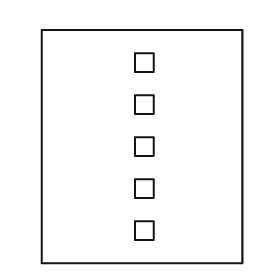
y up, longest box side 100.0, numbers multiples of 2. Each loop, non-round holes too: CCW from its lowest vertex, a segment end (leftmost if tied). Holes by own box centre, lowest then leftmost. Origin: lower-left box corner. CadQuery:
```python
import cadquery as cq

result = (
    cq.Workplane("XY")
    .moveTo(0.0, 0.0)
    .lineTo(86.0, 0.0)
    .lineTo(86.0, 100.0)
    .lineTo(0.0, 100.0)
    .close()
    .moveTo(40.0, 10.0)
    .lineTo(48.0, 10.0)
    .lineTo(48.0, 18.0)
    .lineTo(40.0, 18.0)
    .close()
    .moveTo(40.0, 28.0)
    .lineTo(48.0, 28.0)
    .lineTo(48.0, 36.0)
    .lineTo(40.0, 36.0)
    .close()
    .moveTo(40.0, 46.0)
    .lineTo(48.0, 46.0)
    .lineTo(48.0, 54.0)
    .lineTo(40.0, 54.0)
    .close()
    .moveTo(40.0, 64.0)
    .lineTo(48.0, 64.0)
    .lineTo(48.0, 72.0)
    .lineTo(40.0, 72.0)
    .close()
    .moveTo(40.0, 82.0)
    .lineTo(48.0, 82.0)
    .lineTo(48.0, 90.0)
    .lineTo(40.0, 90.0)
    .close()
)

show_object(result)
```